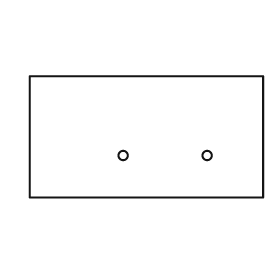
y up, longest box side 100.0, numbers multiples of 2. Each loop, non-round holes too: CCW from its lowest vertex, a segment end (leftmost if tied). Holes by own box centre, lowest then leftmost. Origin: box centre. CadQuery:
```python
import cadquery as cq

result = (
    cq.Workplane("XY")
    .moveTo(-50.0, -26.0)
    .lineTo(50.0, -26.0)
    .lineTo(50.0, 26.0)
    .lineTo(-50.0, 26.0)
    .close()
    .moveTo(-10.0, -8.0)
    .circle(2.0)
    .moveTo(26.0, -8.0)
    .circle(2.0)
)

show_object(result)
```